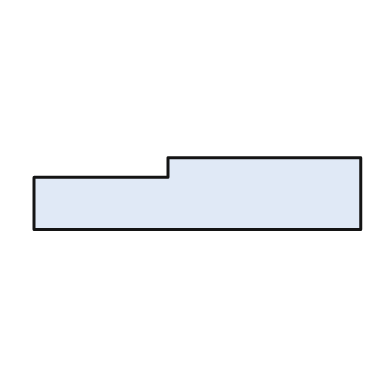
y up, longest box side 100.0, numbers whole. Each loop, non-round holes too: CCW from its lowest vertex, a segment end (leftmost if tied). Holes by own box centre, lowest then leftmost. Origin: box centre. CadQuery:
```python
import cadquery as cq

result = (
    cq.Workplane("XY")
    .moveTo(-50.0, -11.0)
    .lineTo(50.0, -11.0)
    .lineTo(50.0, 11.0)
    .lineTo(-9.0, 11.0)
    .lineTo(-9.0, 5.0)
    .lineTo(-50.0, 5.0)
    .close()
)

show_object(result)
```